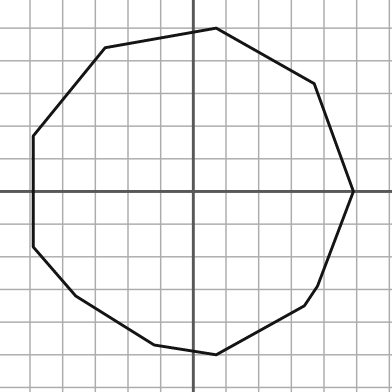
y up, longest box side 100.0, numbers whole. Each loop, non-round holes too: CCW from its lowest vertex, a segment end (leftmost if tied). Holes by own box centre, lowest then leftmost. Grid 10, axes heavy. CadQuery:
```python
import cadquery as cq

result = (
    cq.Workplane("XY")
    .moveTo(7.0, -50.0)
    .lineTo(34.0, -35.0)
    .lineTo(38.0, -29.0)
    .lineTo(49.0, 0.0)
    .lineTo(37.0, 33.0)
    .lineTo(7.0, 50.0)
    .lineTo(-27.0, 44.0)
    .lineTo(-49.0, 17.0)
    .lineTo(-49.0, -17.0)
    .lineTo(-36.0, -32.0)
    .lineTo(-12.0, -47.0)
    .close()
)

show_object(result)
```